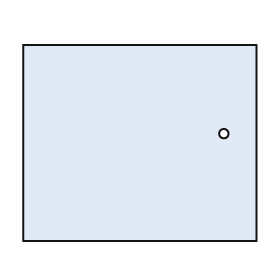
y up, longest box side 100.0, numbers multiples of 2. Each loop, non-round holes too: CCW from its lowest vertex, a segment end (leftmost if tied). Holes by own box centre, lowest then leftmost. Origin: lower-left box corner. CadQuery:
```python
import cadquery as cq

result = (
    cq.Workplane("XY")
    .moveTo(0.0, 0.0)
    .lineTo(100.0, 0.0)
    .lineTo(100.0, 84.0)
    .lineTo(0.0, 84.0)
    .close()
    .moveTo(86.0, 46.0)
    .circle(2.0)
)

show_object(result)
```